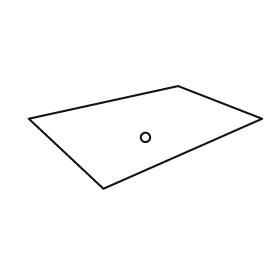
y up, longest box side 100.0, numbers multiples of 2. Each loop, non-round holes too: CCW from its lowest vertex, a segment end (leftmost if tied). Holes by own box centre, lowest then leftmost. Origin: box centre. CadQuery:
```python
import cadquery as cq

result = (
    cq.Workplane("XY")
    .moveTo(-18.0, -22.0)
    .lineTo(50.0, 8.0)
    .lineTo(14.0, 22.0)
    .lineTo(-50.0, 8.0)
    .close()
    .moveTo(0.0, 0.0)
    .circle(2.0)
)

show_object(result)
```